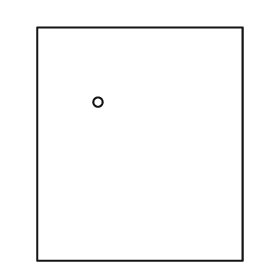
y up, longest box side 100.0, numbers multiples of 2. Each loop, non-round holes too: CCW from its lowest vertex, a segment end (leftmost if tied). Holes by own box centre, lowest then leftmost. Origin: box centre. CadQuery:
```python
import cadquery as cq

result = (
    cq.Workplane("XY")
    .moveTo(-44.0, -50.0)
    .lineTo(44.0, -50.0)
    .lineTo(44.0, 50.0)
    .lineTo(-44.0, 50.0)
    .close()
    .moveTo(-18.0, 18.0)
    .circle(2.0)
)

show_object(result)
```